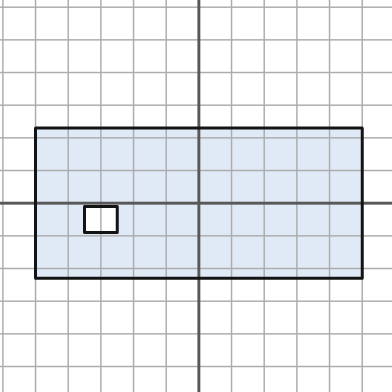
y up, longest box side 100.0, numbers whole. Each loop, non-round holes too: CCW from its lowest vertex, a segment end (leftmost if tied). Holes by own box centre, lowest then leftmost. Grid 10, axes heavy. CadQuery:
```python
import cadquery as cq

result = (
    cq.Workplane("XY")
    .moveTo(-50.0, -23.0)
    .lineTo(50.0, -23.0)
    .lineTo(50.0, 23.0)
    .lineTo(-50.0, 23.0)
    .close()
    .moveTo(-35.0, -9.0)
    .lineTo(-25.0, -9.0)
    .lineTo(-25.0, -1.0)
    .lineTo(-35.0, -1.0)
    .close()
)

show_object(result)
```